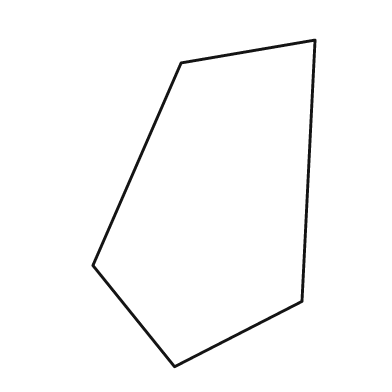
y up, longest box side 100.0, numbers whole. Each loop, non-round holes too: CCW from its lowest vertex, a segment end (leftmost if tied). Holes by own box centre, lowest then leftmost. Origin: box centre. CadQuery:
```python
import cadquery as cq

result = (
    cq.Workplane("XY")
    .moveTo(-9.0, -50.0)
    .lineTo(30.0, -30.0)
    .lineTo(34.0, 50.0)
    .lineTo(-7.0, 43.0)
    .lineTo(-34.0, -19.0)
    .close()
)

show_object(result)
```